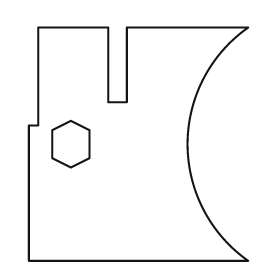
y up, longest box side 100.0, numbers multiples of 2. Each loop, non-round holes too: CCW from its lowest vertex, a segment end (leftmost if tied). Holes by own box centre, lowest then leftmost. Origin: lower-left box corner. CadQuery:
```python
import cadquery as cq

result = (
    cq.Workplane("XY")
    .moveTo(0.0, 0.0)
    .lineTo(94.0, 0.0)
    .threePointArc((68.0, 50.0), (94.0, 100.0))
    .lineTo(42.0, 100.0)
    .lineTo(42.0, 68.0)
    .lineTo(34.0, 68.0)
    .lineTo(34.0, 100.0)
    .lineTo(4.0, 100.0)
    .lineTo(4.0, 58.0)
    .lineTo(0.0, 58.0)
    .close()
    .moveTo(18.0, 40.0)
    .lineTo(26.0, 44.0)
    .lineTo(26.0, 56.0)
    .lineTo(18.0, 60.0)
    .lineTo(10.0, 56.0)
    .lineTo(10.0, 44.0)
    .close()
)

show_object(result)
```